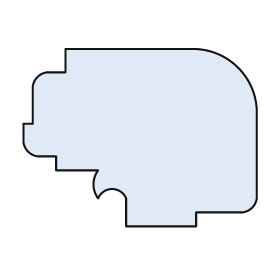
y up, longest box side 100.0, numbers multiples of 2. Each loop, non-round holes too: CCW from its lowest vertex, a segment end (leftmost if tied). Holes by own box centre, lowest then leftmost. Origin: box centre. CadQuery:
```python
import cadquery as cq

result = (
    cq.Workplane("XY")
    .moveTo(-6.0, -38.0)
    .lineTo(24.0, -38.0)
    .lineTo(24.0, -32.0)
    .lineTo(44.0, -32.0)
    .threePointArc((48.0, -30.0), (50.0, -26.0))
    .lineTo(50.0, 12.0)
    .threePointArc((42.0, 30.0), (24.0, 38.0))
    .lineTo(-32.0, 38.0)
    .lineTo(-32.0, 28.0)
    .lineTo(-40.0, 28.0)
    .threePointArc((-44.0, 26.0), (-46.0, 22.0))
    .lineTo(-46.0, 6.0)
    .lineTo(-50.0, 6.0)
    .lineTo(-50.0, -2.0)
    .threePointArc((-48.0, -6.0), (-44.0, -8.0))
    .lineTo(-36.0, -8.0)
    .lineTo(-36.0, -14.0)
    .lineTo(-18.0, -14.0)
    .threePointArc((-20.0, -20.0), (-18.0, -26.0))
    .threePointArc((-12.0, -22.0), (-6.0, -26.0))
    .close()
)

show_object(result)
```